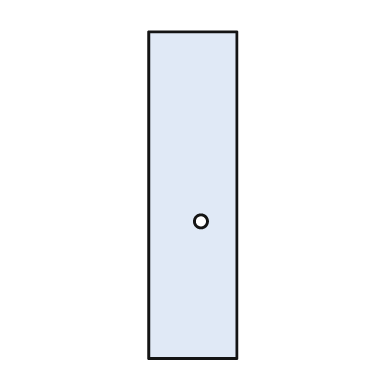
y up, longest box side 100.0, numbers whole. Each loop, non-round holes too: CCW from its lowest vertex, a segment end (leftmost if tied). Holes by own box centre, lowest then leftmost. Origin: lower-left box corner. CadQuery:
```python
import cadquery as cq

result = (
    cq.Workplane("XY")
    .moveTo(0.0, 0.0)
    .lineTo(27.0, 0.0)
    .lineTo(27.0, 100.0)
    .lineTo(0.0, 100.0)
    .close()
    .moveTo(16.0, 42.0)
    .circle(2.0)
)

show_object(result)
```